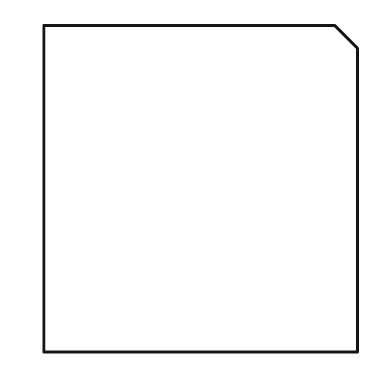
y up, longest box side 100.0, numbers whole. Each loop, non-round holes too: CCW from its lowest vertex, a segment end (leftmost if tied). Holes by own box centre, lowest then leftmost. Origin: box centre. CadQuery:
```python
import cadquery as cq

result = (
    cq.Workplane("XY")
    .moveTo(-48.0, -50.0)
    .lineTo(48.0, -50.0)
    .lineTo(48.0, 43.0)
    .lineTo(41.0, 50.0)
    .lineTo(-48.0, 50.0)
    .close()
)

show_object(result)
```